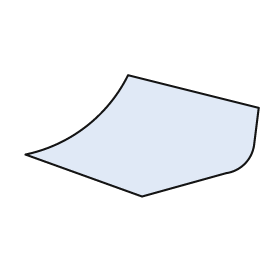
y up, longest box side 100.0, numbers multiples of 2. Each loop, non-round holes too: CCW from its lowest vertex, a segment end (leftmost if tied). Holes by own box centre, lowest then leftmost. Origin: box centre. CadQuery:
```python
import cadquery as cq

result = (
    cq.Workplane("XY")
    .moveTo(0.0, -26.0)
    .lineTo(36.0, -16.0)
    .threePointArc((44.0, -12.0), (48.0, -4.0))
    .lineTo(50.0, 12.0)
    .lineTo(-6.0, 26.0)
    .threePointArc((-24.0, 4.0), (-50.0, -8.0))
    .close()
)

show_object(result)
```